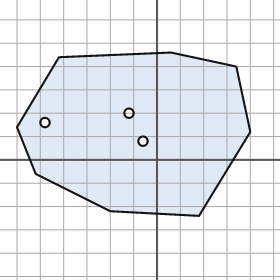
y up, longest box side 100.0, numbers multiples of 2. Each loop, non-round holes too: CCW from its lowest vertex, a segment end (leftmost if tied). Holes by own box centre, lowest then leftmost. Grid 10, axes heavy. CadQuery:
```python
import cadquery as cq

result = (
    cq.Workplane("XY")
    .moveTo(18.0, -24.0)
    .lineTo(40.0, 12.0)
    .lineTo(34.0, 40.0)
    .lineTo(6.0, 46.0)
    .lineTo(-42.0, 44.0)
    .lineTo(-60.0, 14.0)
    .lineTo(-52.0, -6.0)
    .lineTo(-20.0, -22.0)
    .close()
    .moveTo(-6.0, 8.0)
    .circle(2.0)
    .moveTo(-48.0, 16.0)
    .circle(2.0)
    .moveTo(-12.0, 20.0)
    .circle(2.0)
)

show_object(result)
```